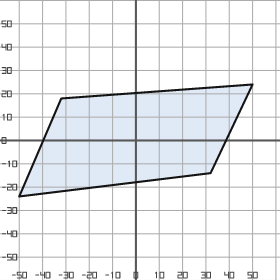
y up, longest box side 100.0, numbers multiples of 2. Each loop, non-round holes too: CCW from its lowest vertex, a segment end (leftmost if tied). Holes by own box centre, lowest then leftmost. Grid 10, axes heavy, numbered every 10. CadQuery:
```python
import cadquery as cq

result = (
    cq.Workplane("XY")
    .moveTo(-50.0, -24.0)
    .lineTo(32.0, -14.0)
    .lineTo(50.0, 24.0)
    .lineTo(-32.0, 18.0)
    .close()
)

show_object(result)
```